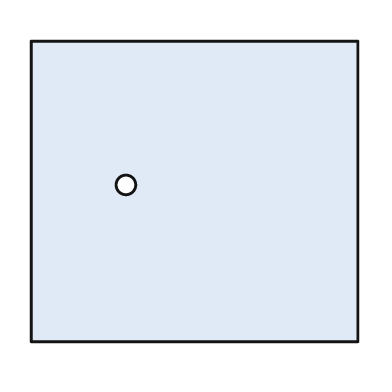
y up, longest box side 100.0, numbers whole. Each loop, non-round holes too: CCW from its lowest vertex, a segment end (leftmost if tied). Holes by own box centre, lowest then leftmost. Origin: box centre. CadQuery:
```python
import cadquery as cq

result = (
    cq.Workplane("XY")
    .moveTo(-50.0, -46.0)
    .lineTo(50.0, -46.0)
    .lineTo(50.0, 46.0)
    .lineTo(-50.0, 46.0)
    .close()
    .moveTo(-21.0, 2.0)
    .circle(3.0)
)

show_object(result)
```